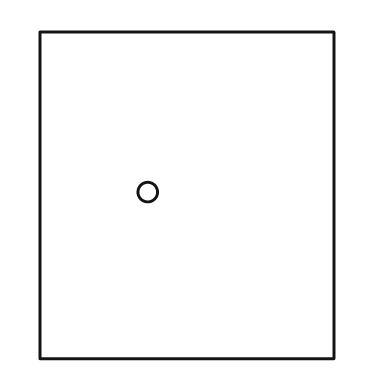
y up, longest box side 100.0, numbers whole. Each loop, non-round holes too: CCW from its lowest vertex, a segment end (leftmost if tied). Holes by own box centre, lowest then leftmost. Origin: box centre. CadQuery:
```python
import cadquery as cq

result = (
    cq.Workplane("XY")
    .moveTo(-45.0, -50.0)
    .lineTo(45.0, -50.0)
    .lineTo(45.0, 50.0)
    .lineTo(-45.0, 50.0)
    .close()
    .moveTo(-12.0, 1.0)
    .circle(3.0)
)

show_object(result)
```